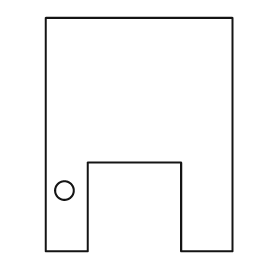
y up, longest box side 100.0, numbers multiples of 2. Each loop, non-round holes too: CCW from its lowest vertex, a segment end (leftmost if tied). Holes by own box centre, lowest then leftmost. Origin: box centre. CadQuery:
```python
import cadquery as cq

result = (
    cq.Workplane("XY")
    .moveTo(-40.0, -50.0)
    .lineTo(-22.0, -50.0)
    .lineTo(-22.0, -12.0)
    .lineTo(18.0, -12.0)
    .lineTo(18.0, -50.0)
    .lineTo(40.0, -50.0)
    .lineTo(40.0, 50.0)
    .lineTo(-40.0, 50.0)
    .close()
    .moveTo(-32.0, -24.0)
    .circle(4.0)
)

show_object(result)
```